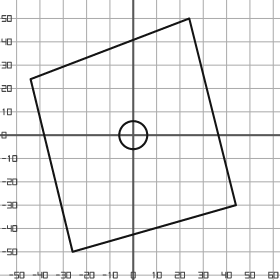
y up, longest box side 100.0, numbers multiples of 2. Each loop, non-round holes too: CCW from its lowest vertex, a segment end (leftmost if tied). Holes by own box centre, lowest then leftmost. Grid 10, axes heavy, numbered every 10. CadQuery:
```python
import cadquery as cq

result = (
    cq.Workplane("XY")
    .moveTo(-26.0, -50.0)
    .lineTo(44.0, -30.0)
    .lineTo(24.0, 50.0)
    .lineTo(-44.0, 24.0)
    .close()
    .moveTo(0.0, 0.0)
    .circle(6.0)
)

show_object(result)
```